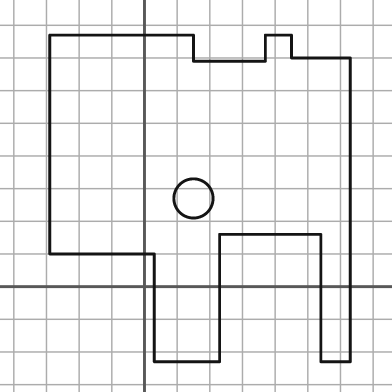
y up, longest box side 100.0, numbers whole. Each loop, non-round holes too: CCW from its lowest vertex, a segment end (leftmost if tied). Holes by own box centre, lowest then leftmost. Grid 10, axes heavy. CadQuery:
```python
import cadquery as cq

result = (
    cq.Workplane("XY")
    .moveTo(3.0, -23.0)
    .lineTo(23.0, -23.0)
    .lineTo(23.0, 16.0)
    .lineTo(54.0, 16.0)
    .lineTo(54.0, -23.0)
    .lineTo(63.0, -23.0)
    .lineTo(63.0, 70.0)
    .lineTo(45.0, 70.0)
    .lineTo(45.0, 77.0)
    .lineTo(37.0, 77.0)
    .lineTo(37.0, 69.0)
    .lineTo(15.0, 69.0)
    .lineTo(15.0, 77.0)
    .lineTo(-29.0, 77.0)
    .lineTo(-29.0, 10.0)
    .lineTo(3.0, 10.0)
    .close()
    .moveTo(15.0, 27.0)
    .circle(6.0)
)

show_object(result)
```